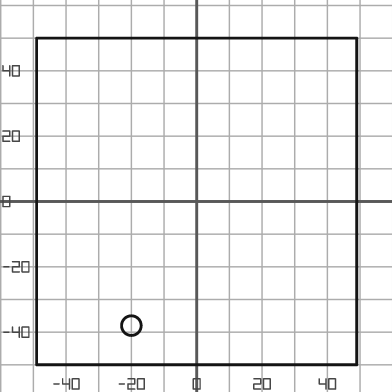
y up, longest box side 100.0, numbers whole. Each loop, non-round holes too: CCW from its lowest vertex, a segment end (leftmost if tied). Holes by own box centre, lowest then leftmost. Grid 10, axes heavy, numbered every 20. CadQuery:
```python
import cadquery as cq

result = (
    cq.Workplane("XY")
    .moveTo(-49.0, -50.0)
    .lineTo(49.0, -50.0)
    .lineTo(49.0, 50.0)
    .lineTo(-49.0, 50.0)
    .close()
    .moveTo(-20.0, -38.0)
    .circle(3.0)
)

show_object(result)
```